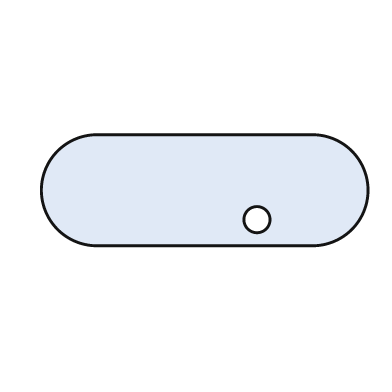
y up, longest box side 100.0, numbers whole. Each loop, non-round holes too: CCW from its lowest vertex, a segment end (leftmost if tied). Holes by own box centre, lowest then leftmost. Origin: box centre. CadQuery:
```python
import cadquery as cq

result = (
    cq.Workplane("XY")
    .moveTo(-33.0, -17.0)
    .lineTo(33.0, -17.0)
    .threePointArc((50.0, 0.0), (33.0, 17.0))
    .lineTo(-33.0, 17.0)
    .threePointArc((-50.0, 0.0), (-33.0, -17.0))
    .close()
    .moveTo(16.0, -9.0)
    .circle(4.0)
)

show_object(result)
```